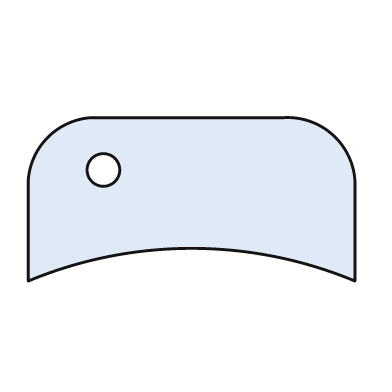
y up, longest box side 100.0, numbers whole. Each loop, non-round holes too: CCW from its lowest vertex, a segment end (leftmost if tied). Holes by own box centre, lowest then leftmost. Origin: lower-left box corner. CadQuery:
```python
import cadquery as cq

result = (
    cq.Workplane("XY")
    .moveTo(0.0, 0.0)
    .threePointArc((50.0, 10.0), (100.0, 0.0))
    .lineTo(100.0, 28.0)
    .threePointArc((94.0, 44.0), (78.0, 50.0))
    .lineTo(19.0, 50.0)
    .threePointArc((6.0, 44.0), (0.0, 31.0))
    .close()
    .moveTo(23.0, 34.0)
    .circle(5.0)
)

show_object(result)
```